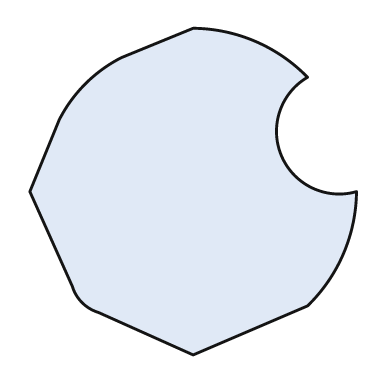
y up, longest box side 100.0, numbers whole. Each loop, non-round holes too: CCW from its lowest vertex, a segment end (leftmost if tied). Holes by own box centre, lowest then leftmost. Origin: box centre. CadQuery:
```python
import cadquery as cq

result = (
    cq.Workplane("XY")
    .moveTo(0.0, -50.0)
    .lineTo(35.0, -35.0)
    .threePointArc((46.0, -19.0), (50.0, 0.0))
    .threePointArc((27.0, 11.0), (35.0, 35.0))
    .threePointArc((19.0, 46.0), (0.0, 50.0))
    .lineTo(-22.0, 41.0)
    .threePointArc((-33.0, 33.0), (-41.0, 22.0))
    .lineTo(-50.0, 0.0)
    .lineTo(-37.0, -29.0)
    .threePointArc((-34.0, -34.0), (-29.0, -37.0))
    .close()
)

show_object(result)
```